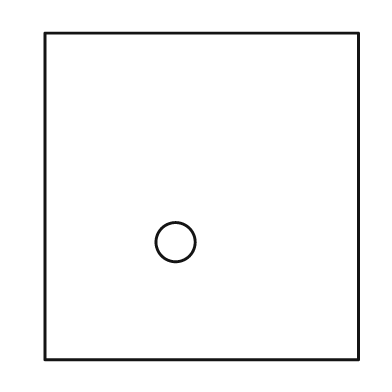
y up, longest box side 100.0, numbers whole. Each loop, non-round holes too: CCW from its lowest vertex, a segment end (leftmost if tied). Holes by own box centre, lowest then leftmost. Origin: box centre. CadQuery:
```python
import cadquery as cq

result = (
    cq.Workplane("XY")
    .moveTo(-48.0, -50.0)
    .lineTo(48.0, -50.0)
    .lineTo(48.0, 50.0)
    .lineTo(-48.0, 50.0)
    .close()
    .moveTo(-8.0, -14.0)
    .circle(6.0)
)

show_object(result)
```